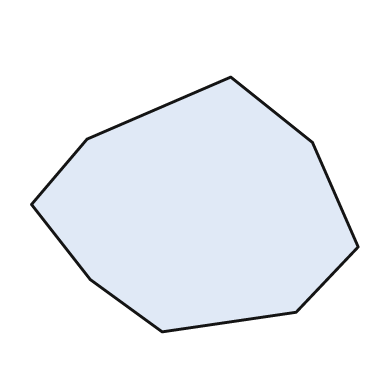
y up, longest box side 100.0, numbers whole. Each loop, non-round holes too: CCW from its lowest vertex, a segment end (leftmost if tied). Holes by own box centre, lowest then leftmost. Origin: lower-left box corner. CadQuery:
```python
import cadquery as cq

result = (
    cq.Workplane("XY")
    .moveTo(40.0, 0.0)
    .lineTo(81.0, 6.0)
    .lineTo(100.0, 26.0)
    .lineTo(86.0, 58.0)
    .lineTo(61.0, 78.0)
    .lineTo(17.0, 59.0)
    .lineTo(0.0, 39.0)
    .lineTo(18.0, 16.0)
    .close()
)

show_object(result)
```